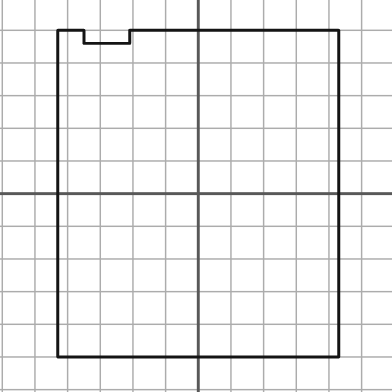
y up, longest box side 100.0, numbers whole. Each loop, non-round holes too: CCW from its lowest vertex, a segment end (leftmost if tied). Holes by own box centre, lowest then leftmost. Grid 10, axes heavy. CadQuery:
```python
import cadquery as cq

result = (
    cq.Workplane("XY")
    .moveTo(-43.0, -50.0)
    .lineTo(43.0, -50.0)
    .lineTo(43.0, 50.0)
    .lineTo(-21.0, 50.0)
    .lineTo(-21.0, 46.0)
    .lineTo(-35.0, 46.0)
    .lineTo(-35.0, 50.0)
    .lineTo(-43.0, 50.0)
    .close()
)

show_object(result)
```